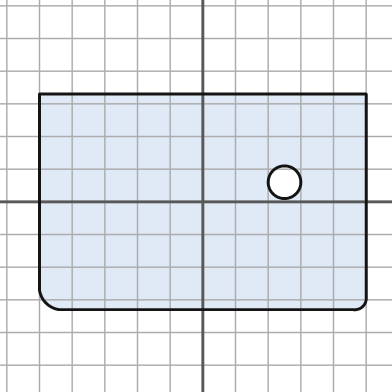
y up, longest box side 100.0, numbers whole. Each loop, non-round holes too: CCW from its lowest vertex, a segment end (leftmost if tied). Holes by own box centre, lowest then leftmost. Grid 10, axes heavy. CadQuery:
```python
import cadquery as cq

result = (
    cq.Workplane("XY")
    .moveTo(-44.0, -33.0)
    .lineTo(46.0, -33.0)
    .threePointArc((49.0, -32.0), (50.0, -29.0))
    .lineTo(50.0, 33.0)
    .lineTo(-50.0, 33.0)
    .lineTo(-50.0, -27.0)
    .threePointArc((-48.0, -31.0), (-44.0, -33.0))
    .close()
    .moveTo(25.0, 6.0)
    .circle(5.0)
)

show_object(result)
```